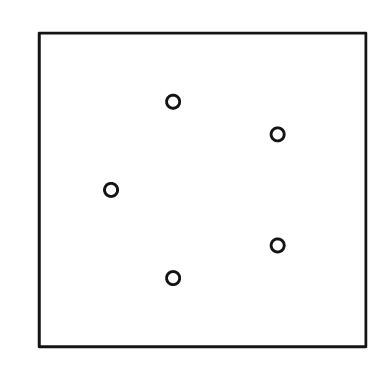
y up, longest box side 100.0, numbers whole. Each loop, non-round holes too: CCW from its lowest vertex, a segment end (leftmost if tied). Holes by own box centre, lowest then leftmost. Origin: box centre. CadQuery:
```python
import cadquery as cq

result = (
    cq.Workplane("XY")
    .moveTo(-50.0, -48.0)
    .lineTo(50.0, -48.0)
    .lineTo(50.0, 48.0)
    .lineTo(-50.0, 48.0)
    .close()
    .moveTo(-9.0, -27.0)
    .circle(2.0)
    .moveTo(23.0, -17.0)
    .circle(2.0)
    .moveTo(-28.0, 0.0)
    .circle(2.0)
    .moveTo(23.0, 17.0)
    .circle(2.0)
    .moveTo(-9.0, 27.0)
    .circle(2.0)
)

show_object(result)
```